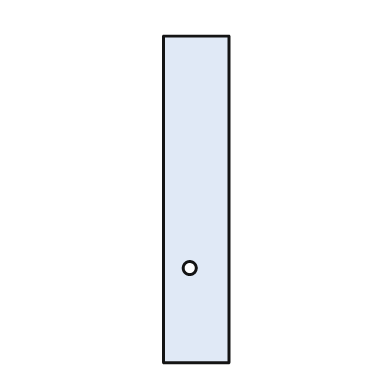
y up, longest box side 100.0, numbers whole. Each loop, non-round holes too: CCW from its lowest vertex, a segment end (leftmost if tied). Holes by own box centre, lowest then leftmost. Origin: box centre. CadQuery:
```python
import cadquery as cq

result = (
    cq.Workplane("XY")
    .moveTo(-10.0, -50.0)
    .lineTo(10.0, -50.0)
    .lineTo(10.0, 50.0)
    .lineTo(-10.0, 50.0)
    .close()
    .moveTo(-2.0, -21.0)
    .circle(2.0)
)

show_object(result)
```